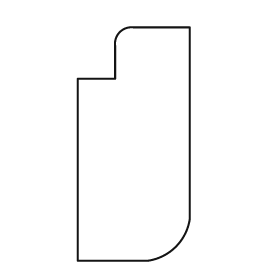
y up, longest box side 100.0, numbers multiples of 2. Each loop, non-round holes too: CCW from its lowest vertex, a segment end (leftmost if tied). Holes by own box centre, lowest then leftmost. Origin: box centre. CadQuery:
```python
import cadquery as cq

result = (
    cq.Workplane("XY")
    .moveTo(-24.0, -50.0)
    .lineTo(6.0, -50.0)
    .threePointArc((18.0, -44.0), (24.0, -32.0))
    .lineTo(24.0, 50.0)
    .lineTo(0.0, 50.0)
    .threePointArc((-6.0, 48.0), (-8.0, 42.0))
    .lineTo(-8.0, 28.0)
    .lineTo(-24.0, 28.0)
    .close()
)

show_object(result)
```